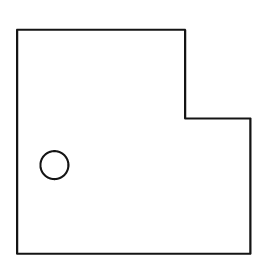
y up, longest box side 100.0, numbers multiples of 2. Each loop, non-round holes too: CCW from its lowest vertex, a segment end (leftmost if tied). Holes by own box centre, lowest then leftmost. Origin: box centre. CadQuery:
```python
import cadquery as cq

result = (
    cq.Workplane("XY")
    .moveTo(-50.0, -48.0)
    .lineTo(50.0, -48.0)
    .lineTo(50.0, 10.0)
    .lineTo(22.0, 10.0)
    .lineTo(22.0, 48.0)
    .lineTo(-50.0, 48.0)
    .close()
    .moveTo(-34.0, -10.0)
    .circle(6.0)
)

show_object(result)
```